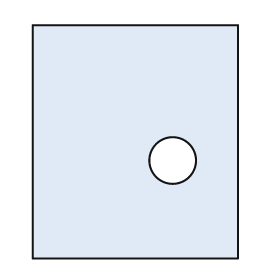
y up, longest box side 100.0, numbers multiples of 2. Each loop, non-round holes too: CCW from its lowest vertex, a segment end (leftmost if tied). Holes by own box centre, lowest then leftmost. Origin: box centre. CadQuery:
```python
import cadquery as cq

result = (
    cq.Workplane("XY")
    .moveTo(-44.0, -50.0)
    .lineTo(44.0, -50.0)
    .lineTo(44.0, 50.0)
    .lineTo(-44.0, 50.0)
    .close()
    .moveTo(16.0, -8.0)
    .circle(10.0)
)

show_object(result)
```